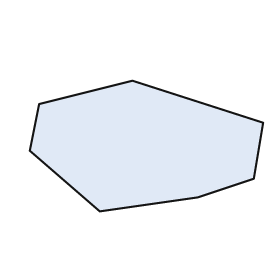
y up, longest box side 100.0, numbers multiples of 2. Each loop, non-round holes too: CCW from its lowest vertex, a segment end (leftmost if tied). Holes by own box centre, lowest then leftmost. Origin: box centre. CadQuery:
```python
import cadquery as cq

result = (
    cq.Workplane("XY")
    .moveTo(-20.0, -28.0)
    .lineTo(22.0, -22.0)
    .lineTo(46.0, -14.0)
    .lineTo(50.0, 10.0)
    .lineTo(-6.0, 28.0)
    .lineTo(-46.0, 18.0)
    .lineTo(-50.0, -2.0)
    .close()
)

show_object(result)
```